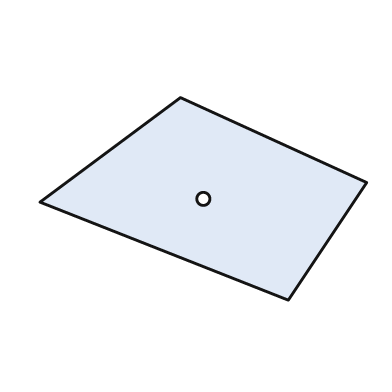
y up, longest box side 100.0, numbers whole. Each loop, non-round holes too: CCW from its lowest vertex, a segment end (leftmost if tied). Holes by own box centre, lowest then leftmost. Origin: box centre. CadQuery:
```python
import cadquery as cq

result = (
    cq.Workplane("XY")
    .moveTo(26.0, -31.0)
    .lineTo(50.0, 5.0)
    .lineTo(-7.0, 31.0)
    .lineTo(-50.0, -1.0)
    .close()
    .moveTo(0.0, 0.0)
    .circle(2.0)
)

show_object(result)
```